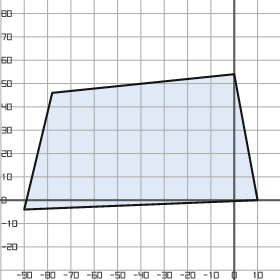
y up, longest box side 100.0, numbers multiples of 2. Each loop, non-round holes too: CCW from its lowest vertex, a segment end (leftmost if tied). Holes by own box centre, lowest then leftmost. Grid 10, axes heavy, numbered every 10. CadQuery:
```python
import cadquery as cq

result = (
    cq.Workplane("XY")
    .moveTo(-90.0, -4.0)
    .lineTo(10.0, 0.0)
    .lineTo(0.0, 54.0)
    .lineTo(-78.0, 46.0)
    .close()
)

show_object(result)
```